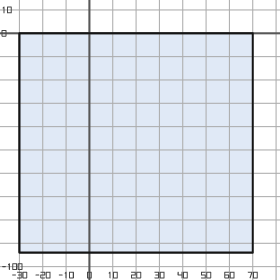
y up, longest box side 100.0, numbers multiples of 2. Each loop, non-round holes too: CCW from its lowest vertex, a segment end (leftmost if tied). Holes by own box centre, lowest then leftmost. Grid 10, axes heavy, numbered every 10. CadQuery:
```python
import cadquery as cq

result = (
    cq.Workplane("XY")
    .moveTo(-30.0, -94.0)
    .lineTo(70.0, -94.0)
    .lineTo(70.0, 0.0)
    .lineTo(-30.0, 0.0)
    .close()
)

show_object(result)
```